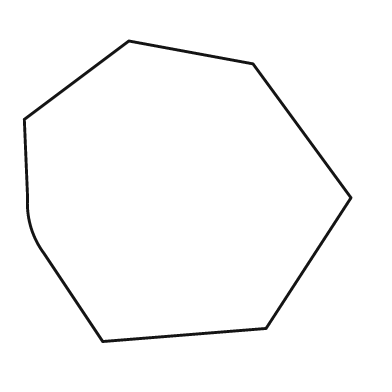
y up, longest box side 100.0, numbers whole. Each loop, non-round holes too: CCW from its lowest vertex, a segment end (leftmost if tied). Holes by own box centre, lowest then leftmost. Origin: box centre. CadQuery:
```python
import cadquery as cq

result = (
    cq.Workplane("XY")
    .moveTo(-26.0, -46.0)
    .lineTo(24.0, -42.0)
    .lineTo(50.0, -2.0)
    .lineTo(20.0, 39.0)
    .lineTo(-18.0, 46.0)
    .lineTo(-50.0, 22.0)
    .lineTo(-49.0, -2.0)
    .threePointArc((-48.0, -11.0), (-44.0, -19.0))
    .close()
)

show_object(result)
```